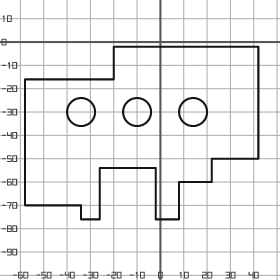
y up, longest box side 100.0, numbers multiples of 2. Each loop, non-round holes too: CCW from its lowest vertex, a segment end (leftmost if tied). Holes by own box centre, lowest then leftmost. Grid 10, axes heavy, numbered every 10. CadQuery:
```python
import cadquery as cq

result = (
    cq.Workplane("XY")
    .moveTo(-34.0, -76.0)
    .lineTo(-26.0, -76.0)
    .lineTo(-26.0, -54.0)
    .lineTo(-2.0, -54.0)
    .lineTo(-2.0, -76.0)
    .lineTo(8.0, -76.0)
    .lineTo(8.0, -60.0)
    .lineTo(22.0, -60.0)
    .lineTo(22.0, -50.0)
    .lineTo(42.0, -50.0)
    .lineTo(42.0, -2.0)
    .lineTo(-20.0, -2.0)
    .lineTo(-20.0, -16.0)
    .lineTo(-58.0, -16.0)
    .lineTo(-58.0, -70.0)
    .lineTo(-34.0, -70.0)
    .close()
    .moveTo(-34.0, -30.0)
    .circle(6.0)
    .moveTo(-10.0, -30.0)
    .circle(6.0)
    .moveTo(14.0, -30.0)
    .circle(6.0)
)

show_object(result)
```